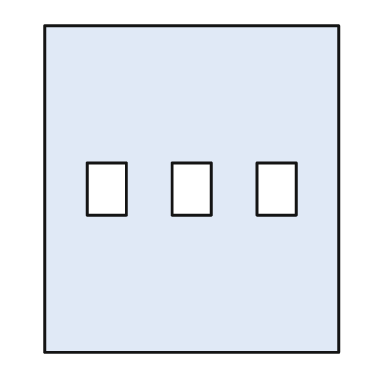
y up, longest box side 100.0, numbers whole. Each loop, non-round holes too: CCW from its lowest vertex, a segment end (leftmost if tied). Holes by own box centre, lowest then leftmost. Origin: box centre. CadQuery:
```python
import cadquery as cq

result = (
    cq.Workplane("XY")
    .moveTo(-45.0, -50.0)
    .lineTo(45.0, -50.0)
    .lineTo(45.0, 50.0)
    .lineTo(-45.0, 50.0)
    .close()
    .moveTo(-32.0, -8.0)
    .lineTo(-20.0, -8.0)
    .lineTo(-20.0, 8.0)
    .lineTo(-32.0, 8.0)
    .close()
    .moveTo(-6.0, -8.0)
    .lineTo(6.0, -8.0)
    .lineTo(6.0, 8.0)
    .lineTo(-6.0, 8.0)
    .close()
    .moveTo(20.0, -8.0)
    .lineTo(32.0, -8.0)
    .lineTo(32.0, 8.0)
    .lineTo(20.0, 8.0)
    .close()
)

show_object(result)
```